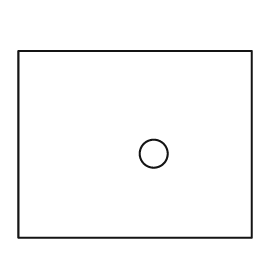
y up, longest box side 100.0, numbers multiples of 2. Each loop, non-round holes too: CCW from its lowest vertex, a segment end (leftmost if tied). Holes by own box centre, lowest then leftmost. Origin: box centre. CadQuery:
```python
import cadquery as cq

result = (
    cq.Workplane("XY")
    .moveTo(-50.0, -40.0)
    .lineTo(50.0, -40.0)
    .lineTo(50.0, 40.0)
    .lineTo(-50.0, 40.0)
    .close()
    .moveTo(8.0, -4.0)
    .circle(6.0)
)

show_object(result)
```